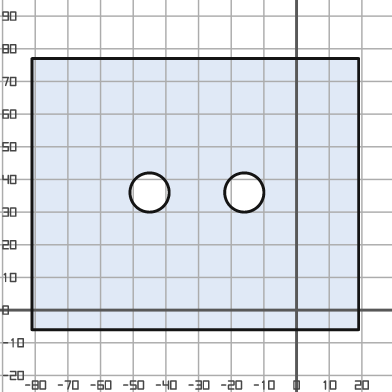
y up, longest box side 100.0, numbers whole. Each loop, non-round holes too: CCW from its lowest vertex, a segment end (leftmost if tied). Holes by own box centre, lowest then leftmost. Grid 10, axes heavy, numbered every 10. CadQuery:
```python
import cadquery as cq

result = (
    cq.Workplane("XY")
    .moveTo(-81.0, -6.0)
    .lineTo(19.0, -6.0)
    .lineTo(19.0, 77.0)
    .lineTo(-81.0, 77.0)
    .close()
    .moveTo(-45.0, 36.0)
    .circle(6.0)
    .moveTo(-16.0, 36.0)
    .circle(6.0)
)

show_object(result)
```